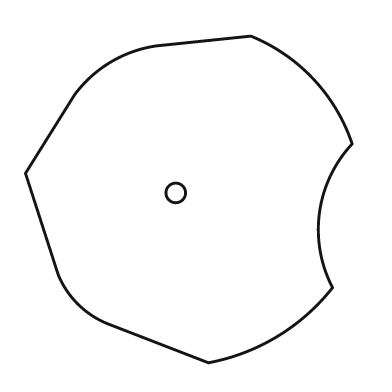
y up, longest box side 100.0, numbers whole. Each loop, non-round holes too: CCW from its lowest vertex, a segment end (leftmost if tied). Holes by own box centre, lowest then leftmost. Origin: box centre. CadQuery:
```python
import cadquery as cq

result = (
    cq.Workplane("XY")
    .moveTo(6.0, -50.0)
    .threePointArc((27.0, -42.0), (44.0, -27.0))
    .threePointArc((40.0, -4.0), (50.0, 17.0))
    .threePointArc((38.0, 37.0), (19.0, 50.0))
    .lineTo(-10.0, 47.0)
    .threePointArc((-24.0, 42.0), (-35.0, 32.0))
    .lineTo(-50.0, 8.0)
    .lineTo(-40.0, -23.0)
    .threePointArc((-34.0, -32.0), (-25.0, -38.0))
    .close()
    .moveTo(-4.0, 2.0)
    .circle(3.0)
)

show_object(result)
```